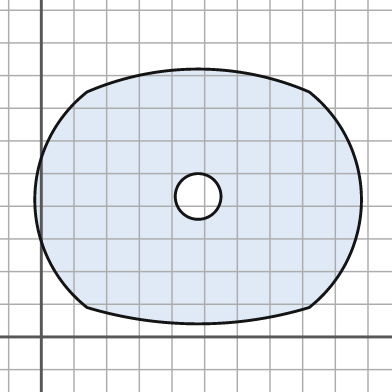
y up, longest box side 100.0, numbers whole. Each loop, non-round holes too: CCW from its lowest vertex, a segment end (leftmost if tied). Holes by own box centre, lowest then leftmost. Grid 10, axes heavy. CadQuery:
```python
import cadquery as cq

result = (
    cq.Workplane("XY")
    .moveTo(14.0, 9.0)
    .threePointArc((48.0, 4.0), (82.0, 9.0))
    .threePointArc((98.0, 42.0), (82.0, 75.0))
    .threePointArc((48.0, 82.0), (14.0, 75.0))
    .threePointArc((-2.0, 42.0), (14.0, 9.0))
    .close()
    .moveTo(48.0, 43.0)
    .circle(7.0)
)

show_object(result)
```